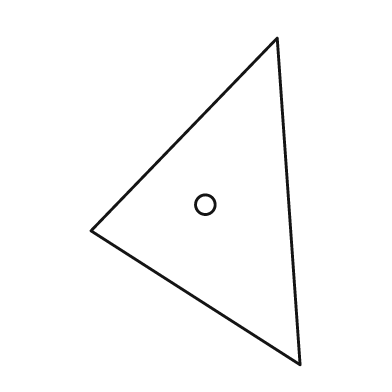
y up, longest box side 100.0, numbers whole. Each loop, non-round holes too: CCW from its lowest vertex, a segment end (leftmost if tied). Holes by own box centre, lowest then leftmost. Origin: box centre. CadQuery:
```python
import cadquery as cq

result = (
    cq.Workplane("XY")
    .moveTo(32.0, -50.0)
    .lineTo(25.0, 50.0)
    .lineTo(-32.0, -9.0)
    .close()
    .moveTo(3.0, -1.0)
    .circle(3.0)
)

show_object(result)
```